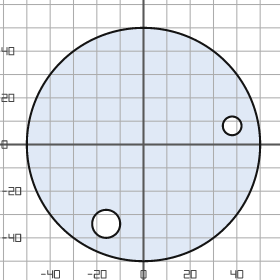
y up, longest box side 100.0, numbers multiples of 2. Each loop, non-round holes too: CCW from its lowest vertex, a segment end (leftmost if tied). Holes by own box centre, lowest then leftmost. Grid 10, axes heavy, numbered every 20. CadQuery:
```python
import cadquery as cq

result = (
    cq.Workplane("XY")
    .moveTo(0.0, 0.0)
    .circle(50.0)
    .moveTo(-16.0, -34.0)
    .circle(6.0)
    .moveTo(38.0, 8.0)
    .circle(4.0)
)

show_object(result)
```